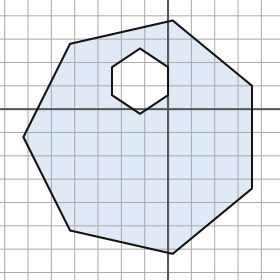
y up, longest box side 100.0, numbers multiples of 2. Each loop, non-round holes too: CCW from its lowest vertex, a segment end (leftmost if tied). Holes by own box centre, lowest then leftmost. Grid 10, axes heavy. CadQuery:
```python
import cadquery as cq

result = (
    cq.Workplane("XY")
    .moveTo(2.0, -62.0)
    .lineTo(36.0, -34.0)
    .lineTo(36.0, 10.0)
    .lineTo(2.0, 38.0)
    .lineTo(-42.0, 28.0)
    .lineTo(-62.0, -12.0)
    .lineTo(-42.0, -52.0)
    .close()
    .moveTo(-12.0, -2.0)
    .lineTo(0.0, 6.0)
    .lineTo(0.0, 18.0)
    .lineTo(-12.0, 26.0)
    .lineTo(-24.0, 18.0)
    .lineTo(-24.0, 6.0)
    .close()
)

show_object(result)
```